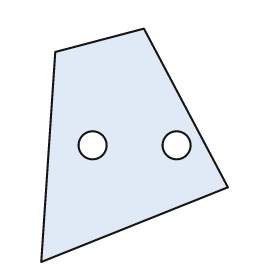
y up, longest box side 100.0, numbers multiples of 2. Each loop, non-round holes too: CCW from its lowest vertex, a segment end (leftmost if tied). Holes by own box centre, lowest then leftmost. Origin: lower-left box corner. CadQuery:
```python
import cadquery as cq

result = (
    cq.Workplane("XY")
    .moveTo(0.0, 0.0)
    .lineTo(80.0, 32.0)
    .lineTo(44.0, 100.0)
    .lineTo(6.0, 90.0)
    .close()
    .moveTo(22.0, 50.0)
    .circle(6.0)
    .moveTo(58.0, 50.0)
    .circle(6.0)
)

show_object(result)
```